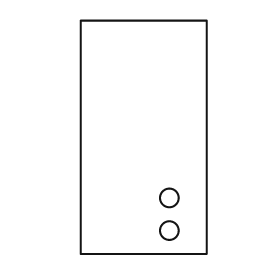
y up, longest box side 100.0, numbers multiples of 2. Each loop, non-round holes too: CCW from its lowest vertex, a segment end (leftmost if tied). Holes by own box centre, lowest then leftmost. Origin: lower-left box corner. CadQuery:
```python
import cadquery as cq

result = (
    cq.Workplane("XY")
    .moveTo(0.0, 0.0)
    .lineTo(54.0, 0.0)
    .lineTo(54.0, 100.0)
    .lineTo(0.0, 100.0)
    .close()
    .moveTo(38.0, 10.0)
    .circle(4.0)
    .moveTo(38.0, 24.0)
    .circle(4.0)
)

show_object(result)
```